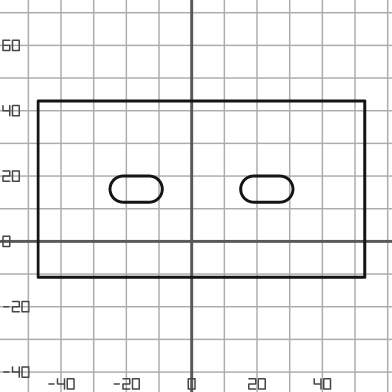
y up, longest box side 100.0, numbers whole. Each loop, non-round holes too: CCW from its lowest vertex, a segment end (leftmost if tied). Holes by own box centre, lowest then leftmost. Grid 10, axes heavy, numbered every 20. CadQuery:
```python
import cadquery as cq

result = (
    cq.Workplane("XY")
    .moveTo(-47.0, -11.0)
    .lineTo(53.0, -11.0)
    .lineTo(53.0, 43.0)
    .lineTo(-47.0, 43.0)
    .close()
    .moveTo(-21.0, 12.0)
    .lineTo(-13.0, 12.0)
    .threePointArc((-9.0, 16.0), (-13.0, 20.0))
    .lineTo(-21.0, 20.0)
    .threePointArc((-25.0, 16.0), (-21.0, 12.0))
    .close()
    .moveTo(19.0, 12.0)
    .lineTo(27.0, 12.0)
    .threePointArc((31.0, 16.0), (27.0, 20.0))
    .lineTo(19.0, 20.0)
    .threePointArc((15.0, 16.0), (19.0, 12.0))
    .close()
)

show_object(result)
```